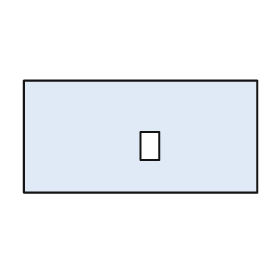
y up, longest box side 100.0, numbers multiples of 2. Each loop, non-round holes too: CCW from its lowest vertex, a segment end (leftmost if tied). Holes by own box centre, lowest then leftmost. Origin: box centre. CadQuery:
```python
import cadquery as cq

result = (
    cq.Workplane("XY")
    .moveTo(-50.0, -24.0)
    .lineTo(50.0, -24.0)
    .lineTo(50.0, 24.0)
    .lineTo(-50.0, 24.0)
    .close()
    .moveTo(0.0, -10.0)
    .lineTo(8.0, -10.0)
    .lineTo(8.0, 2.0)
    .lineTo(0.0, 2.0)
    .close()
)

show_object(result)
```